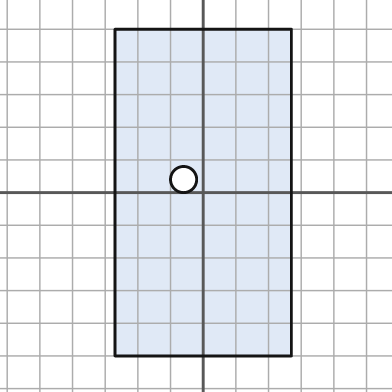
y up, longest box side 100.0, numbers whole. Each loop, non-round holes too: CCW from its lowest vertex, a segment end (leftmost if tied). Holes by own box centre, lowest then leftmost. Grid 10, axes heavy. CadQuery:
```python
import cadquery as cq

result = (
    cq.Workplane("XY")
    .moveTo(-27.0, -50.0)
    .lineTo(27.0, -50.0)
    .lineTo(27.0, 50.0)
    .lineTo(-27.0, 50.0)
    .close()
    .moveTo(-6.0, 4.0)
    .circle(4.0)
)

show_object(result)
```